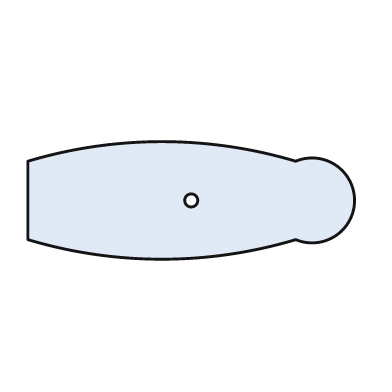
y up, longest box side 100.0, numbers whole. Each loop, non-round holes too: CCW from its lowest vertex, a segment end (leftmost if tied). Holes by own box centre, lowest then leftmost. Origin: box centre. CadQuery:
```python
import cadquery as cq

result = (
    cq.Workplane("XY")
    .moveTo(-50.0, -12.0)
    .threePointArc((-9.0, -18.0), (32.0, -12.0))
    .threePointArc((50.0, 0.0), (32.0, 12.0))
    .threePointArc((-9.0, 18.0), (-50.0, 12.0))
    .close()
    .moveTo(0.0, 0.0)
    .circle(2.0)
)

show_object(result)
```